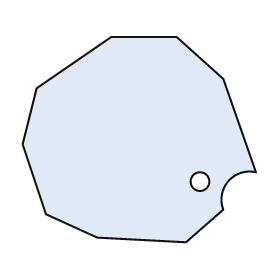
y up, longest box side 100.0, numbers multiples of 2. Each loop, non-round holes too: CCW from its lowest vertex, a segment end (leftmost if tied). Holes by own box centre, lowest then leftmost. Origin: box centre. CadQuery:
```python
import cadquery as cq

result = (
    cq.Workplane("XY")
    .moveTo(20.0, -44.0)
    .lineTo(36.0, -30.0)
    .threePointArc((38.0, -18.0), (50.0, -14.0))
    .lineTo(36.0, 26.0)
    .lineTo(16.0, 44.0)
    .lineTo(-12.0, 44.0)
    .lineTo(-44.0, 22.0)
    .lineTo(-50.0, -2.0)
    .lineTo(-40.0, -32.0)
    .lineTo(-18.0, -42.0)
    .close()
    .moveTo(26.0, -18.0)
    .circle(4.0)
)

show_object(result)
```